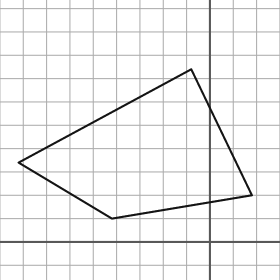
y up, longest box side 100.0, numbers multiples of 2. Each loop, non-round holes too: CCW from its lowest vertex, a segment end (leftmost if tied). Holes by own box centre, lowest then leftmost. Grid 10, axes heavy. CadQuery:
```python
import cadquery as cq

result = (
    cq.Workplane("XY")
    .moveTo(-42.0, 10.0)
    .lineTo(18.0, 20.0)
    .lineTo(-8.0, 74.0)
    .lineTo(-82.0, 34.0)
    .close()
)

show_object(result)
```